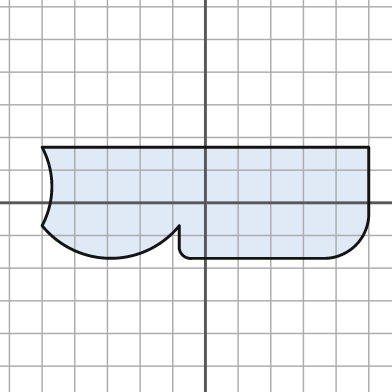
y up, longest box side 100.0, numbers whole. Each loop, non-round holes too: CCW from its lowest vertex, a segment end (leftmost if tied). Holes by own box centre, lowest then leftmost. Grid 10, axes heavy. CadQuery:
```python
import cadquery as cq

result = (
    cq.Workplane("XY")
    .moveTo(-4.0, -17.0)
    .lineTo(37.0, -17.0)
    .threePointArc((46.0, -13.0), (50.0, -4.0))
    .lineTo(50.0, 17.0)
    .lineTo(-50.0, 17.0)
    .threePointArc((-47.0, 5.0), (-50.0, -7.0))
    .threePointArc((-29.0, -17.0), (-8.0, -7.0))
    .lineTo(-8.0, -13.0)
    .threePointArc((-7.0, -16.0), (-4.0, -17.0))
    .close()
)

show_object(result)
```